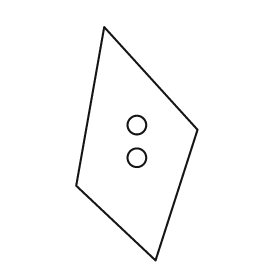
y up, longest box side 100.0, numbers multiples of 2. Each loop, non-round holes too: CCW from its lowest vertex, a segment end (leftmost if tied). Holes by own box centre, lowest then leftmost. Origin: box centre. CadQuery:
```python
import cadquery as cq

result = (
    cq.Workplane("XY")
    .moveTo(8.0, -50.0)
    .lineTo(26.0, 6.0)
    .lineTo(-14.0, 50.0)
    .lineTo(-26.0, -18.0)
    .close()
    .moveTo(0.0, -6.0)
    .circle(4.0)
    .moveTo(0.0, 8.0)
    .circle(4.0)
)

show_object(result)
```